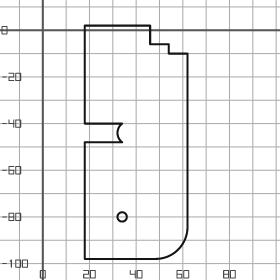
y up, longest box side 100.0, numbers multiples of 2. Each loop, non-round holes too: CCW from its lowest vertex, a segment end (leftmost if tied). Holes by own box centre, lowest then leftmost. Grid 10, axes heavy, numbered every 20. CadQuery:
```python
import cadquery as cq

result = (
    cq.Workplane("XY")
    .moveTo(18.0, -98.0)
    .lineTo(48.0, -98.0)
    .threePointArc((58.0, -94.0), (62.0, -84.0))
    .lineTo(62.0, -10.0)
    .lineTo(54.0, -10.0)
    .lineTo(54.0, -6.0)
    .lineTo(46.0, -6.0)
    .lineTo(46.0, 2.0)
    .lineTo(18.0, 2.0)
    .lineTo(18.0, -40.0)
    .lineTo(34.0, -40.0)
    .threePointArc((32.0, -44.0), (34.0, -48.0))
    .lineTo(18.0, -48.0)
    .close()
    .moveTo(34.0, -80.0)
    .circle(2.0)
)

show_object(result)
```